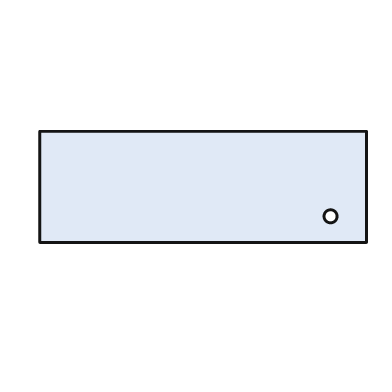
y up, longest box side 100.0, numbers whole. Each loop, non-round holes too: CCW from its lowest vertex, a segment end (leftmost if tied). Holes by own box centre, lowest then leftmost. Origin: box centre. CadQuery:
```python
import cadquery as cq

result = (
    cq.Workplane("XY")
    .moveTo(-50.0, -17.0)
    .lineTo(50.0, -17.0)
    .lineTo(50.0, 17.0)
    .lineTo(-50.0, 17.0)
    .close()
    .moveTo(39.0, -9.0)
    .circle(2.0)
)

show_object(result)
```